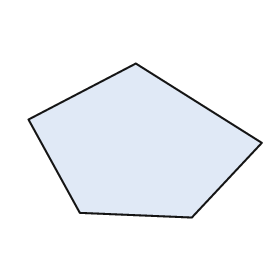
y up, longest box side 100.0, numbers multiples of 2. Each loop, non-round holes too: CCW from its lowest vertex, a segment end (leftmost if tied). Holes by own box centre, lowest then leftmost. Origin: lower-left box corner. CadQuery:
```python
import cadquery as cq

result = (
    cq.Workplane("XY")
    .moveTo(70.0, 0.0)
    .lineTo(100.0, 32.0)
    .lineTo(46.0, 66.0)
    .lineTo(0.0, 42.0)
    .lineTo(22.0, 2.0)
    .close()
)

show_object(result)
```